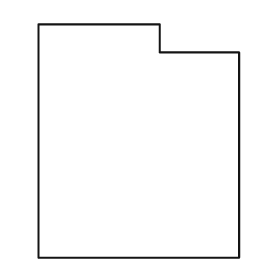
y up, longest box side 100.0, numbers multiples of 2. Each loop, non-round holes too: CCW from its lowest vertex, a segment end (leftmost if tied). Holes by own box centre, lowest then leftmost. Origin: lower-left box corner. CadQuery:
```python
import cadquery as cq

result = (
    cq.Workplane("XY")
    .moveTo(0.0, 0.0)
    .lineTo(86.0, 0.0)
    .lineTo(86.0, 88.0)
    .lineTo(52.0, 88.0)
    .lineTo(52.0, 100.0)
    .lineTo(0.0, 100.0)
    .close()
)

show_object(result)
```